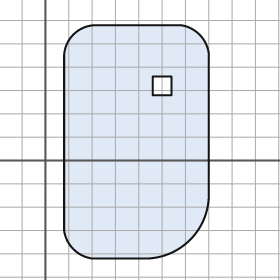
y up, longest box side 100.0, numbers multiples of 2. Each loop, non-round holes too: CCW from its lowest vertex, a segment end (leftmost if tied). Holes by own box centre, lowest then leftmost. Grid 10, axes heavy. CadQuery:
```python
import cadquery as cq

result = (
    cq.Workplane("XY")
    .moveTo(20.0, -42.0)
    .lineTo(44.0, -42.0)
    .threePointArc((62.0, -34.0), (70.0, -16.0))
    .lineTo(70.0, 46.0)
    .threePointArc((66.0, 54.0), (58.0, 58.0))
    .lineTo(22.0, 58.0)
    .threePointArc((12.0, 54.0), (8.0, 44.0))
    .lineTo(8.0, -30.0)
    .threePointArc((12.0, -38.0), (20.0, -42.0))
    .close()
    .moveTo(46.0, 28.0)
    .lineTo(54.0, 28.0)
    .lineTo(54.0, 36.0)
    .lineTo(46.0, 36.0)
    .close()
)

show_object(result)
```